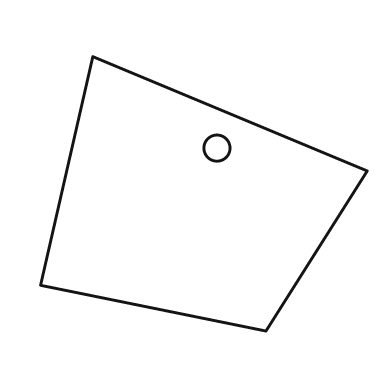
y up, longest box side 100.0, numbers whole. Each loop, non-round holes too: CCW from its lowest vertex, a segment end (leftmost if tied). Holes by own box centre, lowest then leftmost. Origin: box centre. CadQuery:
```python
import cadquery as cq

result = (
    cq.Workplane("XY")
    .moveTo(19.0, -42.0)
    .lineTo(50.0, 7.0)
    .lineTo(-34.0, 42.0)
    .lineTo(-50.0, -28.0)
    .close()
    .moveTo(4.0, 14.0)
    .circle(4.0)
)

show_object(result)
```